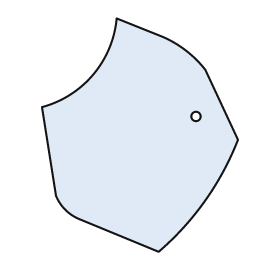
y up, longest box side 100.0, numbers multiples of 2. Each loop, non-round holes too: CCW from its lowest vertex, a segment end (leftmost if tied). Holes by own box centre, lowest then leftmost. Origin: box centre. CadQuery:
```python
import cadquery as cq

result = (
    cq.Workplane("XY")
    .moveTo(8.0, -50.0)
    .threePointArc((28.0, -28.0), (42.0, -2.0))
    .lineTo(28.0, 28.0)
    .threePointArc((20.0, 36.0), (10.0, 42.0))
    .lineTo(-10.0, 50.0)
    .threePointArc((-20.0, 26.0), (-42.0, 12.0))
    .lineTo(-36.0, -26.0)
    .threePointArc((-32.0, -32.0), (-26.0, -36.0))
    .close()
    .moveTo(24.0, 8.0)
    .circle(2.0)
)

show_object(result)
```